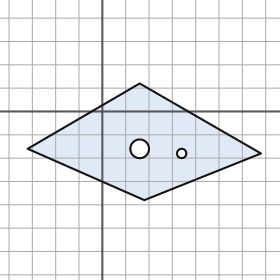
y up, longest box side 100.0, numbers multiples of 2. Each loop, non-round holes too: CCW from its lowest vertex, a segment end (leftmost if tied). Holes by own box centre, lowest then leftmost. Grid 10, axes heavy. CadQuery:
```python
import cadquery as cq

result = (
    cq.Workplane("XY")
    .moveTo(18.0, -38.0)
    .lineTo(68.0, -18.0)
    .lineTo(16.0, 12.0)
    .lineTo(-32.0, -16.0)
    .close()
    .moveTo(34.0, -18.0)
    .circle(2.0)
    .moveTo(16.0, -16.0)
    .circle(4.0)
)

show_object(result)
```